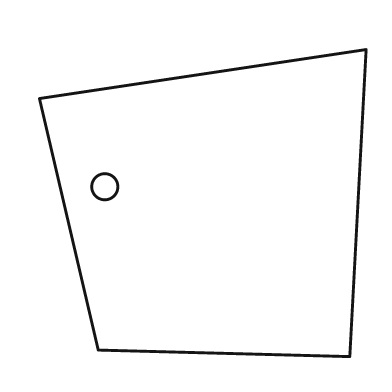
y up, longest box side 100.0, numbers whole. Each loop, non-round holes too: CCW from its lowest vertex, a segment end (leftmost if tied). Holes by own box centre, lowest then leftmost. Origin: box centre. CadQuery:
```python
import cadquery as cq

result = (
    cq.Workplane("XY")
    .moveTo(45.0, -47.0)
    .lineTo(50.0, 47.0)
    .lineTo(-50.0, 32.0)
    .lineTo(-32.0, -45.0)
    .close()
    .moveTo(-30.0, 5.0)
    .circle(4.0)
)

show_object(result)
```